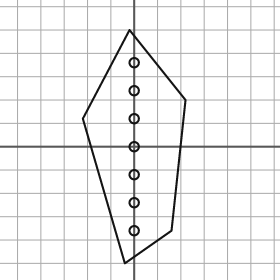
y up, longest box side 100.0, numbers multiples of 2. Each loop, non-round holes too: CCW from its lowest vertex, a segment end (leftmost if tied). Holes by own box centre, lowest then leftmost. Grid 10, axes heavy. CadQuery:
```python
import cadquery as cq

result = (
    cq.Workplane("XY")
    .moveTo(-4.0, -50.0)
    .lineTo(16.0, -36.0)
    .lineTo(22.0, 20.0)
    .lineTo(-2.0, 50.0)
    .lineTo(-22.0, 12.0)
    .close()
    .moveTo(0.0, -36.0)
    .circle(2.0)
    .moveTo(0.0, -24.0)
    .circle(2.0)
    .moveTo(0.0, -12.0)
    .circle(2.0)
    .moveTo(0.0, 0.0)
    .circle(2.0)
    .moveTo(0.0, 12.0)
    .circle(2.0)
    .moveTo(0.0, 24.0)
    .circle(2.0)
    .moveTo(0.0, 36.0)
    .circle(2.0)
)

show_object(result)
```